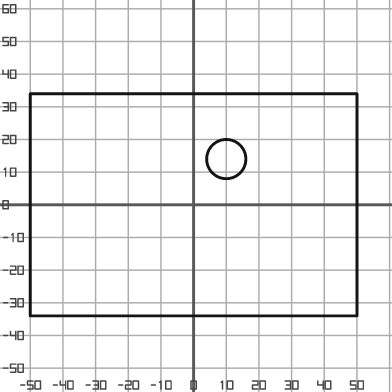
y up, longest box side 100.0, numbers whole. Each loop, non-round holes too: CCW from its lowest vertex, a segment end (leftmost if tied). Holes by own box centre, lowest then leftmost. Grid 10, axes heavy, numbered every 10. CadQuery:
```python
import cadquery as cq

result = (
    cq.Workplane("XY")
    .moveTo(-50.0, -34.0)
    .lineTo(50.0, -34.0)
    .lineTo(50.0, 34.0)
    .lineTo(-50.0, 34.0)
    .close()
    .moveTo(10.0, 14.0)
    .circle(6.0)
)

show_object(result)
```